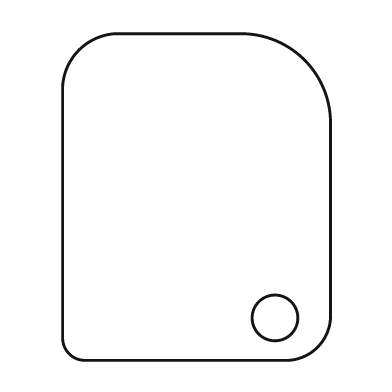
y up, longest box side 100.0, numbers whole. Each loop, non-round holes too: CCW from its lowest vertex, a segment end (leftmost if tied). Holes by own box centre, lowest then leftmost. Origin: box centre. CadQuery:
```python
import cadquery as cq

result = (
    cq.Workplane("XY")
    .moveTo(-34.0, -50.0)
    .lineTo(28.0, -50.0)
    .threePointArc((37.0, -46.0), (41.0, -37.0))
    .lineTo(41.0, 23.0)
    .threePointArc((33.0, 42.0), (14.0, 50.0))
    .lineTo(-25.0, 50.0)
    .threePointArc((-36.0, 45.0), (-41.0, 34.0))
    .lineTo(-41.0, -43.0)
    .threePointArc((-39.0, -48.0), (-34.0, -50.0))
    .close()
    .moveTo(24.0, -37.0)
    .circle(7.0)
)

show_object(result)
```